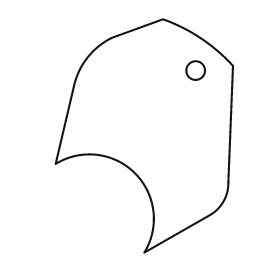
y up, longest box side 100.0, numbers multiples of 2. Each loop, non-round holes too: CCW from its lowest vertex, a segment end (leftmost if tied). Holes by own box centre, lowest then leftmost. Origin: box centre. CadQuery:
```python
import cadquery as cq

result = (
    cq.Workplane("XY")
    .moveTo(0.0, -50.0)
    .lineTo(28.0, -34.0)
    .threePointArc((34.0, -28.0), (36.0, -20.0))
    .lineTo(38.0, 30.0)
    .threePointArc((24.0, 42.0), (8.0, 50.0))
    .lineTo(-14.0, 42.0)
    .threePointArc((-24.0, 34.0), (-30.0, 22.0))
    .lineTo(-38.0, -12.0)
    .threePointArc((-4.0, -16.0), (0.0, -50.0))
    .close()
    .moveTo(22.0, 28.0)
    .circle(4.0)
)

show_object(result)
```